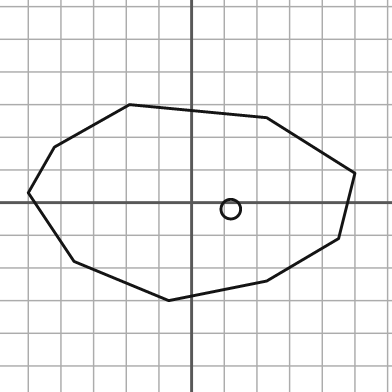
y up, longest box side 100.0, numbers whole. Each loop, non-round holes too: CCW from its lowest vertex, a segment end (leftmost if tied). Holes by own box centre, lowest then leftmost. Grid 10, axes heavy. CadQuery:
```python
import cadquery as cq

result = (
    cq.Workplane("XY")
    .moveTo(-7.0, -30.0)
    .lineTo(23.0, -24.0)
    .lineTo(45.0, -11.0)
    .lineTo(50.0, 9.0)
    .lineTo(23.0, 26.0)
    .lineTo(-19.0, 30.0)
    .lineTo(-42.0, 17.0)
    .lineTo(-50.0, 3.0)
    .lineTo(-36.0, -18.0)
    .close()
    .moveTo(12.0, -2.0)
    .circle(3.0)
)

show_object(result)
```